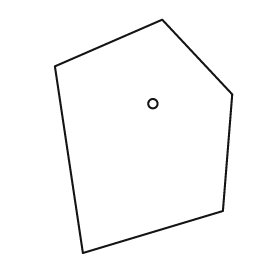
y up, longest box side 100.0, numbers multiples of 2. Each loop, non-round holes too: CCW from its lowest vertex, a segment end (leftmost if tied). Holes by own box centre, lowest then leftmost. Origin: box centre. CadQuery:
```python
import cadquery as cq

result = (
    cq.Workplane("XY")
    .moveTo(-26.0, -50.0)
    .lineTo(34.0, -32.0)
    .lineTo(38.0, 18.0)
    .lineTo(8.0, 50.0)
    .lineTo(-38.0, 30.0)
    .close()
    .moveTo(4.0, 14.0)
    .circle(2.0)
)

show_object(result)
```